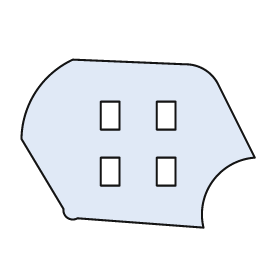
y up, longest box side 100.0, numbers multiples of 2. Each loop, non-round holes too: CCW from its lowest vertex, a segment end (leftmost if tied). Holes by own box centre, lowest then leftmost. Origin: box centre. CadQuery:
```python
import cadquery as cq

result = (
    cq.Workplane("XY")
    .moveTo(28.0, -36.0)
    .threePointArc((32.0, -16.0), (50.0, -6.0))
    .lineTo(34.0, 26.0)
    .threePointArc((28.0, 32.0), (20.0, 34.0))
    .lineTo(-28.0, 36.0)
    .threePointArc((-44.0, 22.0), (-50.0, 2.0))
    .lineTo(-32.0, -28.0)
    .threePointArc((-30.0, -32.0), (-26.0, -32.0))
    .close()
    .moveTo(-16.0, -18.0)
    .lineTo(-8.0, -18.0)
    .lineTo(-8.0, -6.0)
    .lineTo(-16.0, -6.0)
    .close()
    .moveTo(8.0, -18.0)
    .lineTo(16.0, -18.0)
    .lineTo(16.0, -6.0)
    .lineTo(8.0, -6.0)
    .close()
    .moveTo(-16.0, 6.0)
    .lineTo(-8.0, 6.0)
    .lineTo(-8.0, 18.0)
    .lineTo(-16.0, 18.0)
    .close()
    .moveTo(8.0, 6.0)
    .lineTo(16.0, 6.0)
    .lineTo(16.0, 18.0)
    .lineTo(8.0, 18.0)
    .close()
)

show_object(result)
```